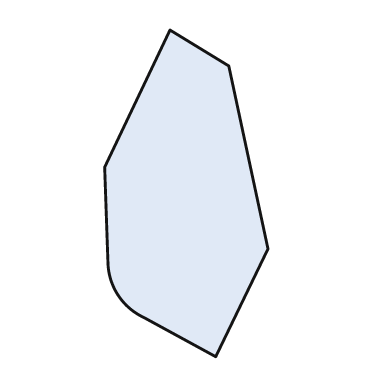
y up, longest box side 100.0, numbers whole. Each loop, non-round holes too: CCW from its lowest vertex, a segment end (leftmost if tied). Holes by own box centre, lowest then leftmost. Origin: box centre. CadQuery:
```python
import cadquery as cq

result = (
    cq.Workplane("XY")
    .moveTo(9.0, -50.0)
    .lineTo(25.0, -17.0)
    .lineTo(13.0, 39.0)
    .lineTo(-5.0, 50.0)
    .lineTo(-25.0, 8.0)
    .lineTo(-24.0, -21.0)
    .threePointArc((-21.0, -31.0), (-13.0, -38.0))
    .close()
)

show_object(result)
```